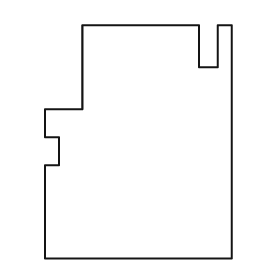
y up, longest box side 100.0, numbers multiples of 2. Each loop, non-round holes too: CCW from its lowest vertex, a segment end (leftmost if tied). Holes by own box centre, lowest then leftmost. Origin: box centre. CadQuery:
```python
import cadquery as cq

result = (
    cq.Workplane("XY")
    .moveTo(-40.0, -50.0)
    .lineTo(40.0, -50.0)
    .lineTo(40.0, 50.0)
    .lineTo(34.0, 50.0)
    .lineTo(34.0, 32.0)
    .lineTo(26.0, 32.0)
    .lineTo(26.0, 50.0)
    .lineTo(-24.0, 50.0)
    .lineTo(-24.0, 14.0)
    .lineTo(-40.0, 14.0)
    .lineTo(-40.0, 2.0)
    .lineTo(-34.0, 2.0)
    .lineTo(-34.0, -10.0)
    .lineTo(-40.0, -10.0)
    .close()
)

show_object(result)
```